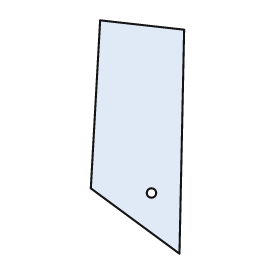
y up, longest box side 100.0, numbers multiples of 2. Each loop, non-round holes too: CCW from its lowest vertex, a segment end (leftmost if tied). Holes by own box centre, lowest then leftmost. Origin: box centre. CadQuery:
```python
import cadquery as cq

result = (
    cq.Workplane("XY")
    .moveTo(18.0, -50.0)
    .lineTo(20.0, 46.0)
    .lineTo(-16.0, 50.0)
    .lineTo(-20.0, -22.0)
    .close()
    .moveTo(6.0, -24.0)
    .circle(2.0)
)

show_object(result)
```